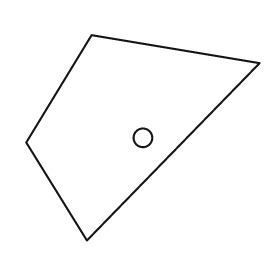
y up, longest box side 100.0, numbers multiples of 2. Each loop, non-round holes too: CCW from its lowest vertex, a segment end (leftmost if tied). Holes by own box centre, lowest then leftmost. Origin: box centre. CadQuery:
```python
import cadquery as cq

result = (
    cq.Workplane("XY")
    .moveTo(-24.0, -44.0)
    .lineTo(50.0, 32.0)
    .lineTo(-22.0, 44.0)
    .lineTo(-50.0, -2.0)
    .close()
    .moveTo(0.0, 0.0)
    .circle(4.0)
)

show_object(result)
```